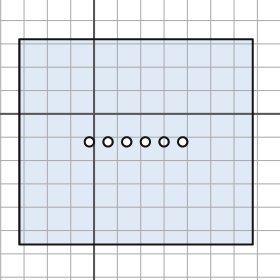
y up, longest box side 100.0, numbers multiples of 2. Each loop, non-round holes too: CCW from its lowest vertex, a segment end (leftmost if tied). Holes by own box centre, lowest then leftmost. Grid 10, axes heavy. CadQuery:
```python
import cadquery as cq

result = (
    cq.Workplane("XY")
    .moveTo(-32.0, -56.0)
    .lineTo(68.0, -56.0)
    .lineTo(68.0, 32.0)
    .lineTo(-32.0, 32.0)
    .close()
    .moveTo(-2.0, -12.0)
    .circle(2.0)
    .moveTo(6.0, -12.0)
    .circle(2.0)
    .moveTo(14.0, -12.0)
    .circle(2.0)
    .moveTo(22.0, -12.0)
    .circle(2.0)
    .moveTo(30.0, -12.0)
    .circle(2.0)
    .moveTo(38.0, -12.0)
    .circle(2.0)
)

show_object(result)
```